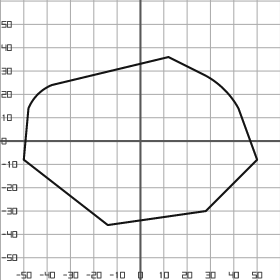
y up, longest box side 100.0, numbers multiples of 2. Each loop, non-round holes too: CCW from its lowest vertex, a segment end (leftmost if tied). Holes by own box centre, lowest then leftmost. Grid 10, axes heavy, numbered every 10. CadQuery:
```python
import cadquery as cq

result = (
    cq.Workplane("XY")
    .moveTo(-14.0, -36.0)
    .lineTo(28.0, -30.0)
    .lineTo(50.0, -8.0)
    .lineTo(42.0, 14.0)
    .threePointArc((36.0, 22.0), (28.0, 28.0))
    .lineTo(12.0, 36.0)
    .lineTo(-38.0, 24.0)
    .threePointArc((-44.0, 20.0), (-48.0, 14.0))
    .lineTo(-50.0, -8.0)
    .close()
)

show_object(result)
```